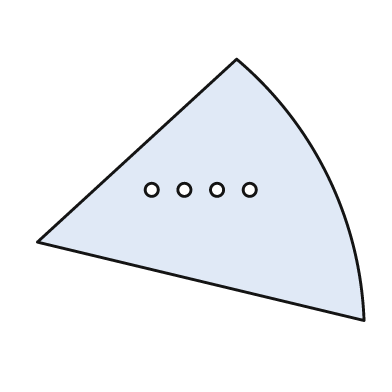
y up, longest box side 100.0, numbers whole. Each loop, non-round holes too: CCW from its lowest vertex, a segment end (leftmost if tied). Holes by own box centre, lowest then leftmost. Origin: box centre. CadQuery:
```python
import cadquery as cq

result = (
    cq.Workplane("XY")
    .moveTo(50.0, -40.0)
    .threePointArc((39.0, 4.0), (11.0, 40.0))
    .lineTo(-50.0, -16.0)
    .close()
    .moveTo(-15.0, 0.0)
    .circle(2.0)
    .moveTo(-5.0, 0.0)
    .circle(2.0)
    .moveTo(5.0, 0.0)
    .circle(2.0)
    .moveTo(15.0, 0.0)
    .circle(2.0)
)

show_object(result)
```